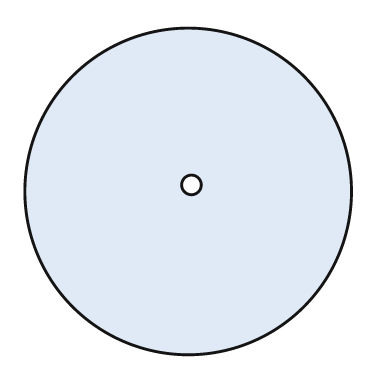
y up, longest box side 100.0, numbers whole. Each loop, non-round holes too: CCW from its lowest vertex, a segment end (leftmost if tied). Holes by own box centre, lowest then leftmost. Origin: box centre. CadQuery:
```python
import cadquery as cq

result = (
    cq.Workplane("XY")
    .moveTo(0.0, 0.0)
    .circle(50.0)
    .moveTo(1.0, 2.0)
    .circle(3.0)
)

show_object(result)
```